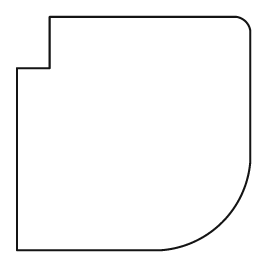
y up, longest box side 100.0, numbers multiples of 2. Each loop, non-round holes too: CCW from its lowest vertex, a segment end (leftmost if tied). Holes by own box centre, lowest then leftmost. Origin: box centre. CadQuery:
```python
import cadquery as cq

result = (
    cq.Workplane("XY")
    .moveTo(-50.0, -50.0)
    .lineTo(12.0, -50.0)
    .threePointArc((38.0, -38.0), (50.0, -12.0))
    .lineTo(50.0, 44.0)
    .threePointArc((48.0, 48.0), (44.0, 50.0))
    .lineTo(-36.0, 50.0)
    .lineTo(-36.0, 28.0)
    .lineTo(-50.0, 28.0)
    .close()
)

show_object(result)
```